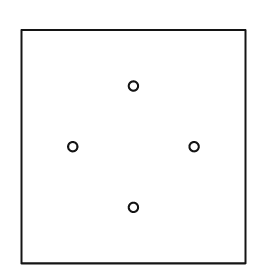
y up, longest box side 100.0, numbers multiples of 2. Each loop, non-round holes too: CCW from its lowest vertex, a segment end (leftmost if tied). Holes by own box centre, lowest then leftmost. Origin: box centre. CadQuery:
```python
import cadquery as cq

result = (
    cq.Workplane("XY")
    .moveTo(-48.0, -50.0)
    .lineTo(48.0, -50.0)
    .lineTo(48.0, 50.0)
    .lineTo(-48.0, 50.0)
    .close()
    .moveTo(0.0, -26.0)
    .circle(2.0)
    .moveTo(-26.0, 0.0)
    .circle(2.0)
    .moveTo(26.0, 0.0)
    .circle(2.0)
    .moveTo(0.0, 26.0)
    .circle(2.0)
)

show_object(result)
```